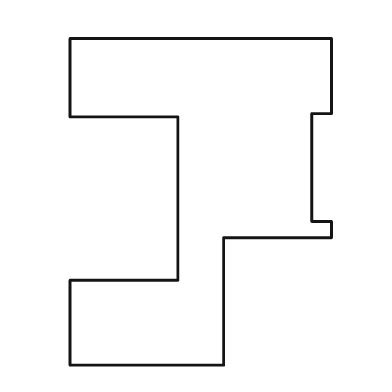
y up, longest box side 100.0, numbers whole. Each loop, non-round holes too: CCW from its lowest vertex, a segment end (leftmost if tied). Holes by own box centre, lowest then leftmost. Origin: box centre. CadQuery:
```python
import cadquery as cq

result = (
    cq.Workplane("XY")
    .moveTo(-40.0, -50.0)
    .lineTo(7.0, -50.0)
    .lineTo(7.0, -11.0)
    .lineTo(40.0, -11.0)
    .lineTo(40.0, -6.0)
    .lineTo(34.0, -6.0)
    .lineTo(34.0, 27.0)
    .lineTo(40.0, 27.0)
    .lineTo(40.0, 50.0)
    .lineTo(-40.0, 50.0)
    .lineTo(-40.0, 26.0)
    .lineTo(-7.0, 26.0)
    .lineTo(-7.0, -24.0)
    .lineTo(-40.0, -24.0)
    .close()
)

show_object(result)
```